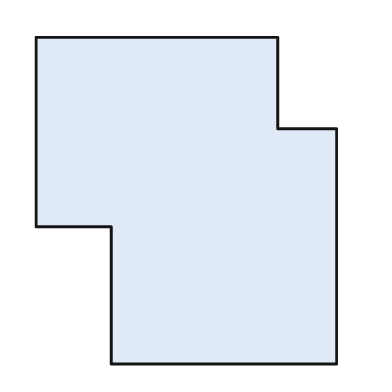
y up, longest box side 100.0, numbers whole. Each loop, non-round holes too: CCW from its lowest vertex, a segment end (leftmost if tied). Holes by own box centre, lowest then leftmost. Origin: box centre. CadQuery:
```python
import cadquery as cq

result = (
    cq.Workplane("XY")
    .moveTo(-23.0, -50.0)
    .lineTo(46.0, -50.0)
    .lineTo(46.0, 22.0)
    .lineTo(28.0, 22.0)
    .lineTo(28.0, 50.0)
    .lineTo(-46.0, 50.0)
    .lineTo(-46.0, -8.0)
    .lineTo(-23.0, -8.0)
    .close()
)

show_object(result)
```